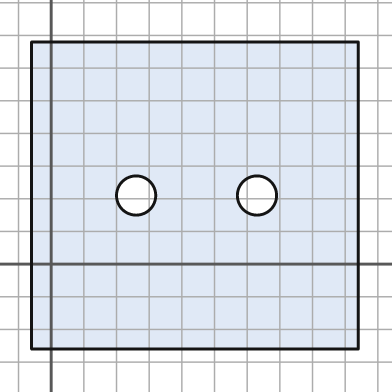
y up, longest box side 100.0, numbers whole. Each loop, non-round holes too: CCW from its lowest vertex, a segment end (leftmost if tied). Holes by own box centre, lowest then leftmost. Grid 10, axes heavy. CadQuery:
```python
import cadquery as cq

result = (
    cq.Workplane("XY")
    .moveTo(-6.0, -26.0)
    .lineTo(94.0, -26.0)
    .lineTo(94.0, 68.0)
    .lineTo(-6.0, 68.0)
    .close()
    .moveTo(26.0, 21.0)
    .circle(6.0)
    .moveTo(63.0, 21.0)
    .circle(6.0)
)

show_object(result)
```